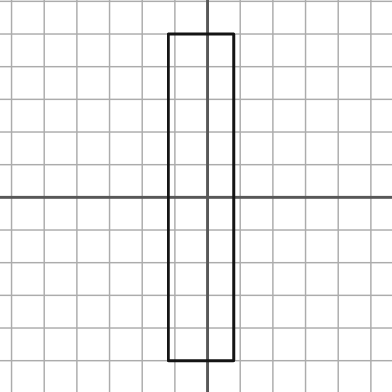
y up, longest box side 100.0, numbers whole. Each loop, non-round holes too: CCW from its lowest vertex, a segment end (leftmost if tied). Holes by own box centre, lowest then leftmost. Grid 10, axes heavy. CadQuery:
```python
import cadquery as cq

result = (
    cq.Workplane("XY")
    .moveTo(-12.0, -50.0)
    .lineTo(8.0, -50.0)
    .lineTo(8.0, 50.0)
    .lineTo(-12.0, 50.0)
    .close()
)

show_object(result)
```